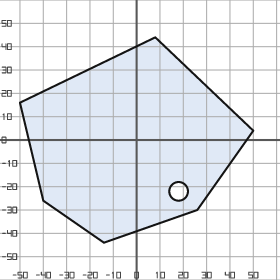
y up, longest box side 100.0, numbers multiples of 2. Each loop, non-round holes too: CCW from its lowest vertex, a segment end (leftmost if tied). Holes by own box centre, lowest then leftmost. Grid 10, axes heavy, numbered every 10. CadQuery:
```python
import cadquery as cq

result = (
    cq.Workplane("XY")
    .moveTo(-14.0, -44.0)
    .lineTo(26.0, -30.0)
    .lineTo(50.0, 4.0)
    .lineTo(8.0, 44.0)
    .lineTo(-50.0, 16.0)
    .lineTo(-40.0, -26.0)
    .close()
    .moveTo(18.0, -22.0)
    .circle(4.0)
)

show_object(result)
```